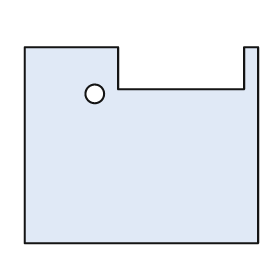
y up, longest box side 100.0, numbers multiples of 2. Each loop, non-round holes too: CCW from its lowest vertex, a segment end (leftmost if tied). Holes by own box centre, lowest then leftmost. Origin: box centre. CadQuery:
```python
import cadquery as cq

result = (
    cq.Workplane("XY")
    .moveTo(-50.0, -42.0)
    .lineTo(50.0, -42.0)
    .lineTo(50.0, 42.0)
    .lineTo(44.0, 42.0)
    .lineTo(44.0, 24.0)
    .lineTo(-10.0, 24.0)
    .lineTo(-10.0, 42.0)
    .lineTo(-50.0, 42.0)
    .close()
    .moveTo(-20.0, 22.0)
    .circle(4.0)
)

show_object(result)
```